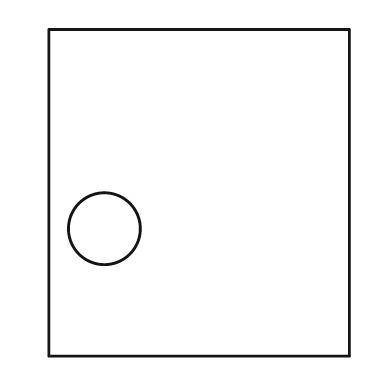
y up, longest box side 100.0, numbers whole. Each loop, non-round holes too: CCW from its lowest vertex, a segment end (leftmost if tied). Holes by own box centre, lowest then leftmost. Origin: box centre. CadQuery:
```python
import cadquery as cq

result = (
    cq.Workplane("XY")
    .moveTo(-46.0, -50.0)
    .lineTo(46.0, -50.0)
    .lineTo(46.0, 50.0)
    .lineTo(-46.0, 50.0)
    .close()
    .moveTo(-29.0, -11.0)
    .circle(11.0)
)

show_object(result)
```